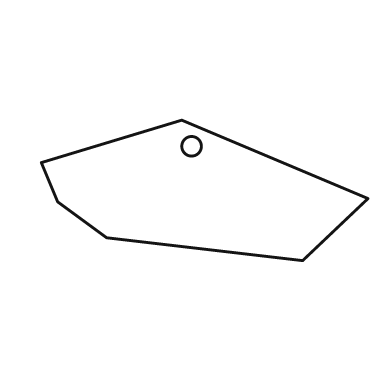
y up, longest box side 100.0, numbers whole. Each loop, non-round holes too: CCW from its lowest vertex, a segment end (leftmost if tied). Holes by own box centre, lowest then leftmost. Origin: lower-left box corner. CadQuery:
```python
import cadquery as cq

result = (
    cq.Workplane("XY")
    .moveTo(80.0, 0.0)
    .lineTo(100.0, 19.0)
    .lineTo(43.0, 43.0)
    .lineTo(0.0, 30.0)
    .lineTo(5.0, 18.0)
    .lineTo(20.0, 7.0)
    .close()
    .moveTo(46.0, 35.0)
    .circle(3.0)
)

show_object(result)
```